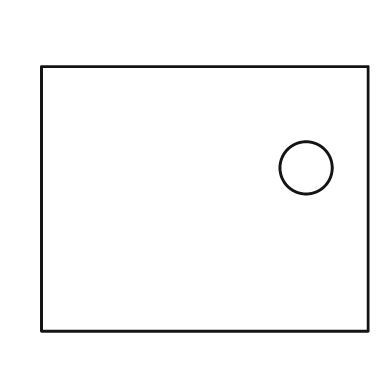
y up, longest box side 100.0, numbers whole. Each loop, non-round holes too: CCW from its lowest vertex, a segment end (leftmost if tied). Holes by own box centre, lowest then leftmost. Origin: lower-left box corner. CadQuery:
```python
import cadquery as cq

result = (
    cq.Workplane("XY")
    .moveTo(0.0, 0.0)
    .lineTo(100.0, 0.0)
    .lineTo(100.0, 81.0)
    .lineTo(0.0, 81.0)
    .close()
    .moveTo(81.0, 50.0)
    .circle(8.0)
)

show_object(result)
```